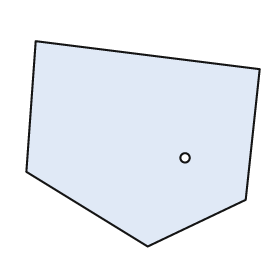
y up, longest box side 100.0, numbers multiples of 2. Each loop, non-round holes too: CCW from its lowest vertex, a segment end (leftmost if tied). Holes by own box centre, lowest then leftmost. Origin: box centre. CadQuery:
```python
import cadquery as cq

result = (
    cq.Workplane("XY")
    .moveTo(2.0, -44.0)
    .lineTo(44.0, -24.0)
    .lineTo(50.0, 32.0)
    .lineTo(-46.0, 44.0)
    .lineTo(-50.0, -12.0)
    .close()
    .moveTo(18.0, -6.0)
    .circle(2.0)
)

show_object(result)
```